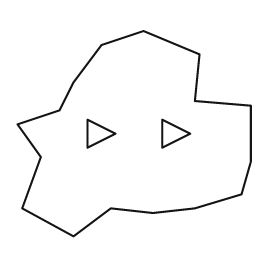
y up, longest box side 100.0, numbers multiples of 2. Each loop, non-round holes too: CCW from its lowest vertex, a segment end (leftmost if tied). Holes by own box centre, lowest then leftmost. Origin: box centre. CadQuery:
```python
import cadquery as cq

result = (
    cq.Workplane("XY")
    .moveTo(-26.0, -44.0)
    .lineTo(-10.0, -32.0)
    .lineTo(8.0, -34.0)
    .lineTo(26.0, -32.0)
    .lineTo(46.0, -26.0)
    .lineTo(50.0, -12.0)
    .lineTo(50.0, 12.0)
    .lineTo(26.0, 14.0)
    .lineTo(28.0, 34.0)
    .lineTo(4.0, 44.0)
    .lineTo(-14.0, 38.0)
    .lineTo(-26.0, 22.0)
    .lineTo(-32.0, 10.0)
    .lineTo(-50.0, 4.0)
    .lineTo(-40.0, -10.0)
    .lineTo(-48.0, -32.0)
    .close()
    .moveTo(-20.0, -6.0)
    .lineTo(-8.0, 0.0)
    .lineTo(-20.0, 6.0)
    .close()
    .moveTo(12.0, -6.0)
    .lineTo(24.0, 0.0)
    .lineTo(12.0, 6.0)
    .close()
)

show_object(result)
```